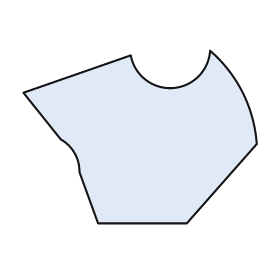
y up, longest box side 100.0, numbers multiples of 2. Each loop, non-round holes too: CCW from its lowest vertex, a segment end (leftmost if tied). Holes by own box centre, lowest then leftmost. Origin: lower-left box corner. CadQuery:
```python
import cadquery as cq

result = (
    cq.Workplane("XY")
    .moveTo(32.0, 0.0)
    .lineTo(70.0, 0.0)
    .lineTo(100.0, 34.0)
    .threePointArc((94.0, 56.0), (80.0, 74.0))
    .threePointArc((64.0, 58.0), (46.0, 72.0))
    .lineTo(0.0, 56.0)
    .lineTo(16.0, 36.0)
    .threePointArc((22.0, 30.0), (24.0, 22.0))
    .close()
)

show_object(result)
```